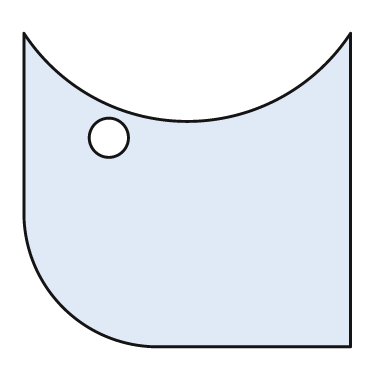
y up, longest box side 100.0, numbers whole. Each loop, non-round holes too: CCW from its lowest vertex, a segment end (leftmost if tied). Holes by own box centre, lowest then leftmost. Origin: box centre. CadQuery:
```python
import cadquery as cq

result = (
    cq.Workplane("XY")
    .moveTo(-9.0, -48.0)
    .lineTo(50.0, -48.0)
    .lineTo(50.0, 48.0)
    .threePointArc((0.0, 21.0), (-50.0, 48.0))
    .lineTo(-50.0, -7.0)
    .threePointArc((-38.0, -36.0), (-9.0, -48.0))
    .close()
    .moveTo(-24.0, 16.0)
    .circle(6.0)
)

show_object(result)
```